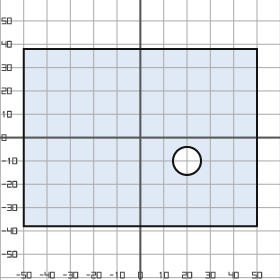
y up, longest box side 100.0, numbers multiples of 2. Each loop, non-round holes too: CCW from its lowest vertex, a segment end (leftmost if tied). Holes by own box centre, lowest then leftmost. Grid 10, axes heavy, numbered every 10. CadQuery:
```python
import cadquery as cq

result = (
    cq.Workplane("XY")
    .moveTo(-50.0, -38.0)
    .lineTo(50.0, -38.0)
    .lineTo(50.0, 38.0)
    .lineTo(-50.0, 38.0)
    .close()
    .moveTo(20.0, -10.0)
    .circle(6.0)
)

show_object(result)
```